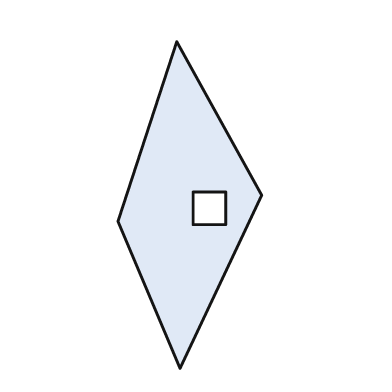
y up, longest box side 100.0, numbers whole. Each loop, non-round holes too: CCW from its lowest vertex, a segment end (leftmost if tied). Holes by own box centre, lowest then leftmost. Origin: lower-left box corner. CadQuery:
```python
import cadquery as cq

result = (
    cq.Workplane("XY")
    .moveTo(19.0, 0.0)
    .lineTo(44.0, 53.0)
    .lineTo(18.0, 100.0)
    .lineTo(0.0, 45.0)
    .close()
    .moveTo(23.0, 44.0)
    .lineTo(33.0, 44.0)
    .lineTo(33.0, 54.0)
    .lineTo(23.0, 54.0)
    .close()
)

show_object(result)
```